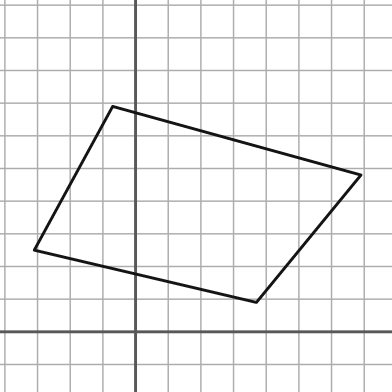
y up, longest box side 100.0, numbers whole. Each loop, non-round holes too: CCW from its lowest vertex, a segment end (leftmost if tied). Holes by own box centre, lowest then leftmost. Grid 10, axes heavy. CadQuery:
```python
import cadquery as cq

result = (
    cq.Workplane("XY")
    .moveTo(37.0, 9.0)
    .lineTo(69.0, 48.0)
    .lineTo(-7.0, 69.0)
    .lineTo(-31.0, 25.0)
    .close()
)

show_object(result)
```